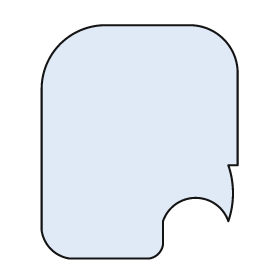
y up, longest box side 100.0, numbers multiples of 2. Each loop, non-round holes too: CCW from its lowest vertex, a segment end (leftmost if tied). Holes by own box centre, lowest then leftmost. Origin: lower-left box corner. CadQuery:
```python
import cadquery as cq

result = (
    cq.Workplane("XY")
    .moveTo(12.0, 0.0)
    .lineTo(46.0, 0.0)
    .threePointArc((50.0, 2.0), (52.0, 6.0))
    .lineTo(52.0, 16.0)
    .threePointArc((66.0, 26.0), (80.0, 16.0))
    .threePointArc((82.0, 28.0), (80.0, 40.0))
    .lineTo(84.0, 40.0)
    .lineTo(84.0, 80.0)
    .threePointArc((78.0, 94.0), (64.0, 100.0))
    .lineTo(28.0, 100.0)
    .threePointArc((8.0, 92.0), (0.0, 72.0))
    .lineTo(0.0, 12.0)
    .threePointArc((4.0, 4.0), (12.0, 0.0))
    .close()
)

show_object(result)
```